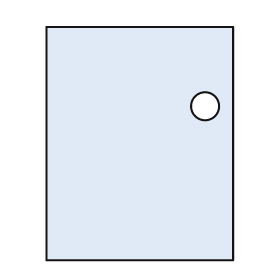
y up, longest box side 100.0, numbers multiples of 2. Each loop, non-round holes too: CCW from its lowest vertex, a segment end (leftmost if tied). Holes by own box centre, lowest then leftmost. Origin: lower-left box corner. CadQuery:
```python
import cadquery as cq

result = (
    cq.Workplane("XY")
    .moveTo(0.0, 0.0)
    .lineTo(80.0, 0.0)
    .lineTo(80.0, 100.0)
    .lineTo(0.0, 100.0)
    .close()
    .moveTo(68.0, 66.0)
    .circle(6.0)
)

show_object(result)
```